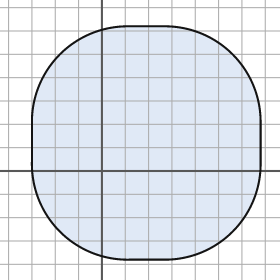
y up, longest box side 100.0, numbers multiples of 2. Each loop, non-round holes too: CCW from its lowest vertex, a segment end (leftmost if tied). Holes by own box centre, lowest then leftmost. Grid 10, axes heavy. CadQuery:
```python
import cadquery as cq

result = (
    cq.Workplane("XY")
    .moveTo(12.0, -38.0)
    .lineTo(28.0, -38.0)
    .threePointArc((56.0, -26.0), (68.0, 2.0))
    .lineTo(68.0, 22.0)
    .threePointArc((56.0, 50.0), (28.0, 62.0))
    .lineTo(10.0, 62.0)
    .threePointArc((-18.0, 50.0), (-30.0, 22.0))
    .lineTo(-30.0, 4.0)
    .threePointArc((-18.0, -26.0), (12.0, -38.0))
    .close()
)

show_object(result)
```